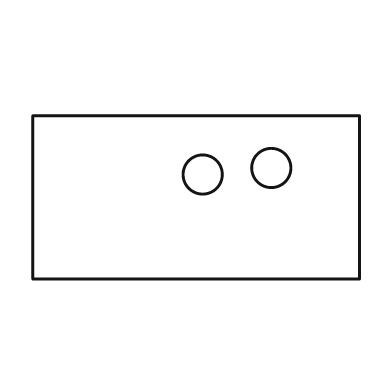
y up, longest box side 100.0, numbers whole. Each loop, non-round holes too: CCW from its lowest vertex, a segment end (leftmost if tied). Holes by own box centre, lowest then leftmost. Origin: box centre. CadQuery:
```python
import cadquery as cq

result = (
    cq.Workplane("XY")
    .moveTo(-50.0, -25.0)
    .lineTo(50.0, -25.0)
    .lineTo(50.0, 25.0)
    .lineTo(-50.0, 25.0)
    .close()
    .moveTo(2.0, 7.0)
    .circle(6.0)
    .moveTo(23.0, 9.0)
    .circle(6.0)
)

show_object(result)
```